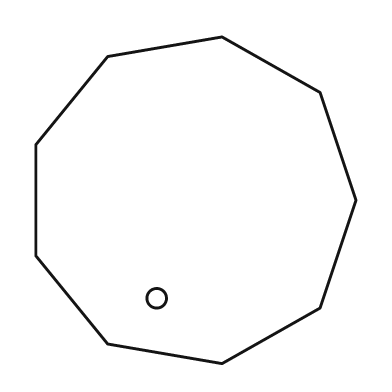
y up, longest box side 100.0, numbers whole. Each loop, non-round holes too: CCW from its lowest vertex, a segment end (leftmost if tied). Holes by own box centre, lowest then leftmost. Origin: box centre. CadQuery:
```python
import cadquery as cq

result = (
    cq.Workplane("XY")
    .moveTo(8.0, -50.0)
    .lineTo(38.0, -33.0)
    .lineTo(49.0, 0.0)
    .lineTo(38.0, 33.0)
    .lineTo(8.0, 50.0)
    .lineTo(-27.0, 44.0)
    .lineTo(-49.0, 17.0)
    .lineTo(-49.0, -17.0)
    .lineTo(-27.0, -44.0)
    .close()
    .moveTo(-12.0, -30.0)
    .circle(3.0)
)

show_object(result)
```